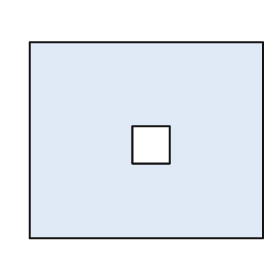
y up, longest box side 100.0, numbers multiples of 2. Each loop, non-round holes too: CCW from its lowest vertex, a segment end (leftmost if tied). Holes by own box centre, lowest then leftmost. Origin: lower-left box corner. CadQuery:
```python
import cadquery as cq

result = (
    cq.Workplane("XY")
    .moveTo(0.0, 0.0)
    .lineTo(100.0, 0.0)
    .lineTo(100.0, 84.0)
    .lineTo(0.0, 84.0)
    .close()
    .moveTo(44.0, 32.0)
    .lineTo(60.0, 32.0)
    .lineTo(60.0, 48.0)
    .lineTo(44.0, 48.0)
    .close()
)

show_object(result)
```